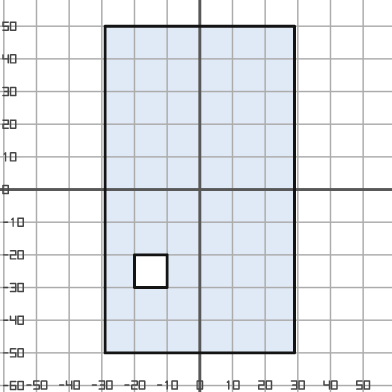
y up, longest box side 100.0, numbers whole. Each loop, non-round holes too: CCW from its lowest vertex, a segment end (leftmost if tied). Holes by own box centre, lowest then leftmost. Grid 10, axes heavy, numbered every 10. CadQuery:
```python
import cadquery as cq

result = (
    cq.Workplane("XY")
    .moveTo(-29.0, -50.0)
    .lineTo(29.0, -50.0)
    .lineTo(29.0, 50.0)
    .lineTo(-29.0, 50.0)
    .close()
    .moveTo(-20.0, -30.0)
    .lineTo(-10.0, -30.0)
    .lineTo(-10.0, -20.0)
    .lineTo(-20.0, -20.0)
    .close()
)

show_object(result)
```